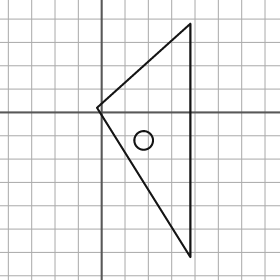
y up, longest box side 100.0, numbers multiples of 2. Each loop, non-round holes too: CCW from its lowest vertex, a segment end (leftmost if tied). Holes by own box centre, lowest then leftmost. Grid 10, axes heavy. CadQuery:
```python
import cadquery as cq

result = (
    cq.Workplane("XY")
    .moveTo(38.0, -62.0)
    .lineTo(38.0, 38.0)
    .lineTo(-2.0, 2.0)
    .close()
    .moveTo(18.0, -12.0)
    .circle(4.0)
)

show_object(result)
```